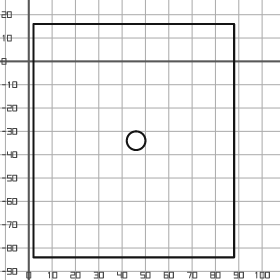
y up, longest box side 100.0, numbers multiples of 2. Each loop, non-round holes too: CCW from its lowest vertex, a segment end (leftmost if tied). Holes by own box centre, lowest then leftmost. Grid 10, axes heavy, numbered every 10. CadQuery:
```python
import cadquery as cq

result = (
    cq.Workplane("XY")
    .moveTo(2.0, -84.0)
    .lineTo(88.0, -84.0)
    .lineTo(88.0, 16.0)
    .lineTo(2.0, 16.0)
    .close()
    .moveTo(46.0, -34.0)
    .circle(4.0)
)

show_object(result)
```